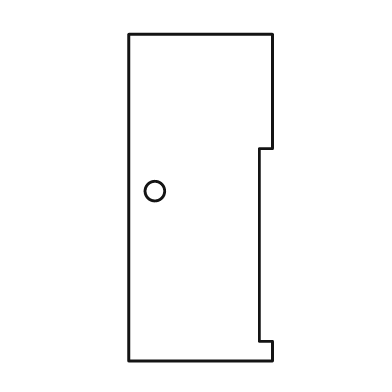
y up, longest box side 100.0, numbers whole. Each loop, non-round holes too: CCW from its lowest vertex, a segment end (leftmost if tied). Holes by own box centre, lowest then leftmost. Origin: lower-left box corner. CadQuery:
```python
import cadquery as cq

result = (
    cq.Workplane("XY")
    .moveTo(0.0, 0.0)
    .lineTo(44.0, 0.0)
    .lineTo(44.0, 6.0)
    .lineTo(40.0, 6.0)
    .lineTo(40.0, 65.0)
    .lineTo(44.0, 65.0)
    .lineTo(44.0, 100.0)
    .lineTo(0.0, 100.0)
    .close()
    .moveTo(8.0, 52.0)
    .circle(3.0)
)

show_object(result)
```